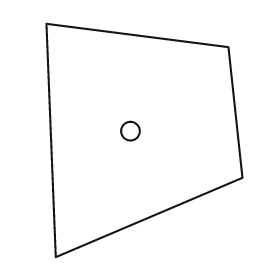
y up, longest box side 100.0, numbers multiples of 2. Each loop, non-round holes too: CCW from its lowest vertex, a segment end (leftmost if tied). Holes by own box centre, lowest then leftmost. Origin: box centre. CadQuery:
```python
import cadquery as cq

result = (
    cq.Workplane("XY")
    .moveTo(-38.0, -50.0)
    .lineTo(42.0, -16.0)
    .lineTo(36.0, 40.0)
    .lineTo(-42.0, 50.0)
    .close()
    .moveTo(-6.0, 4.0)
    .circle(4.0)
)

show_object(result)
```